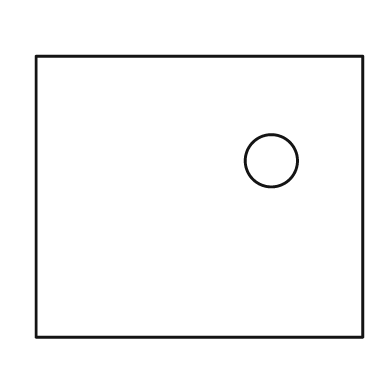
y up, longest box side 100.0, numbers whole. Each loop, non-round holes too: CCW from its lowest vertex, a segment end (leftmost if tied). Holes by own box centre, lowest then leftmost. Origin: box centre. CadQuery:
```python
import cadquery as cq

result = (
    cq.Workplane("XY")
    .moveTo(-50.0, -43.0)
    .lineTo(50.0, -43.0)
    .lineTo(50.0, 43.0)
    .lineTo(-50.0, 43.0)
    .close()
    .moveTo(22.0, 11.0)
    .circle(8.0)
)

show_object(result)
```